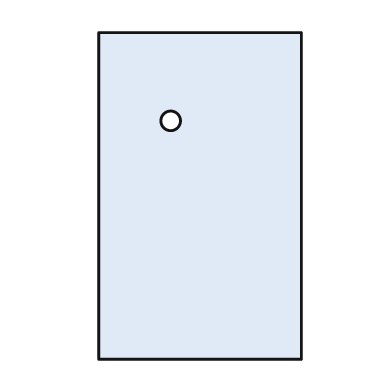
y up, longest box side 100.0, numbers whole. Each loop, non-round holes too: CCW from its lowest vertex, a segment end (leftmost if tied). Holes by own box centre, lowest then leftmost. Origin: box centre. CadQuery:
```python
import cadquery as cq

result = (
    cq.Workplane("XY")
    .moveTo(-31.0, -50.0)
    .lineTo(31.0, -50.0)
    .lineTo(31.0, 50.0)
    .lineTo(-31.0, 50.0)
    .close()
    .moveTo(-9.0, 23.0)
    .circle(3.0)
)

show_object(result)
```